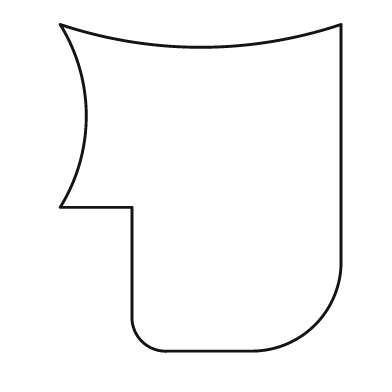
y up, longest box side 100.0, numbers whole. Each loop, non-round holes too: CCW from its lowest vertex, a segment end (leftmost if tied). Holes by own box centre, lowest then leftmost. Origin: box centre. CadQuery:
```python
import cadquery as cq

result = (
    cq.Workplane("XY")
    .moveTo(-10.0, -50.0)
    .lineTo(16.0, -50.0)
    .threePointArc((35.0, -42.0), (43.0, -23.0))
    .lineTo(43.0, 50.0)
    .threePointArc((0.0, 43.0), (-43.0, 50.0))
    .threePointArc((-35.0, 22.0), (-43.0, -6.0))
    .lineTo(-21.0, -6.0)
    .lineTo(-21.0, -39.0)
    .threePointArc((-18.0, -47.0), (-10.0, -50.0))
    .close()
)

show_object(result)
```